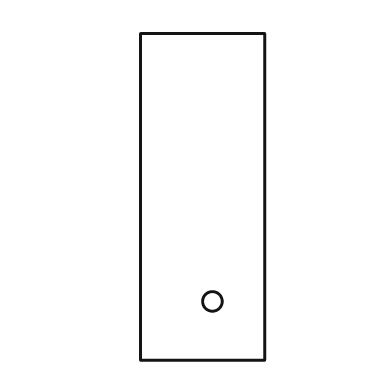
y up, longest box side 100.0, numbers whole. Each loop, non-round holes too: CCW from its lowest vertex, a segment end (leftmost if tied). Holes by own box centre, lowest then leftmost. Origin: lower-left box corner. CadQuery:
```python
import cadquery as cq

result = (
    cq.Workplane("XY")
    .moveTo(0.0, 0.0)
    .lineTo(38.0, 0.0)
    .lineTo(38.0, 100.0)
    .lineTo(0.0, 100.0)
    .close()
    .moveTo(22.0, 18.0)
    .circle(3.0)
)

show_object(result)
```